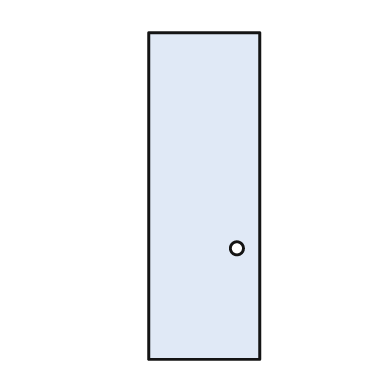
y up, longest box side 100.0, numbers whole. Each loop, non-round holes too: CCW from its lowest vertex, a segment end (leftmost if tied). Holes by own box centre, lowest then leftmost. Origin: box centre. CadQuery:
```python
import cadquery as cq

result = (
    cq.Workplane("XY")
    .moveTo(-17.0, -50.0)
    .lineTo(17.0, -50.0)
    .lineTo(17.0, 50.0)
    .lineTo(-17.0, 50.0)
    .close()
    .moveTo(10.0, -16.0)
    .circle(2.0)
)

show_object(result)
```